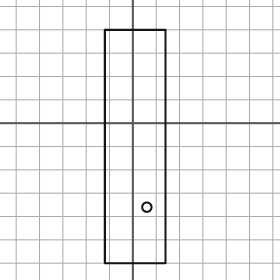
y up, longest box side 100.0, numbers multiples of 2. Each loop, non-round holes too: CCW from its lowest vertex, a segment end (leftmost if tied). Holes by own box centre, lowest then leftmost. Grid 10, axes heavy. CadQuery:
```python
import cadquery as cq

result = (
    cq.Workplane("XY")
    .moveTo(-12.0, -60.0)
    .lineTo(14.0, -60.0)
    .lineTo(14.0, 40.0)
    .lineTo(-12.0, 40.0)
    .close()
    .moveTo(6.0, -36.0)
    .circle(2.0)
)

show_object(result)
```